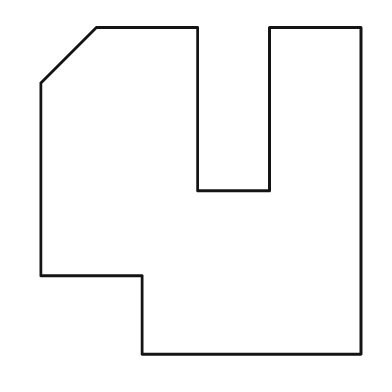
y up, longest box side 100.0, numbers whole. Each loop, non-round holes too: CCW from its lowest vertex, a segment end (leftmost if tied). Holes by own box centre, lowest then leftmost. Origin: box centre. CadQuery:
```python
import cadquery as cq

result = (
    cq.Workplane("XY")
    .moveTo(-18.0, -50.0)
    .lineTo(49.0, -50.0)
    .lineTo(49.0, 50.0)
    .lineTo(21.0, 50.0)
    .lineTo(21.0, 0.0)
    .lineTo(-1.0, 0.0)
    .lineTo(-1.0, 50.0)
    .lineTo(-32.0, 50.0)
    .lineTo(-49.0, 33.0)
    .lineTo(-49.0, -26.0)
    .lineTo(-18.0, -26.0)
    .close()
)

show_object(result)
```